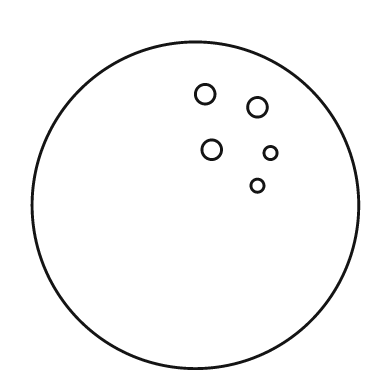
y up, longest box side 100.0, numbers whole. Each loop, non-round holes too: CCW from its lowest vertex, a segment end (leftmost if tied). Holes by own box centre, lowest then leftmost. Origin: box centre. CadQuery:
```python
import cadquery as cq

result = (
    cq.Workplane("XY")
    .moveTo(0.0, 0.0)
    .circle(50.0)
    .moveTo(19.0, 6.0)
    .circle(2.0)
    .moveTo(23.0, 16.0)
    .circle(2.0)
    .moveTo(5.0, 17.0)
    .circle(3.0)
    .moveTo(19.0, 30.0)
    .circle(3.0)
    .moveTo(3.0, 34.0)
    .circle(3.0)
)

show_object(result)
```